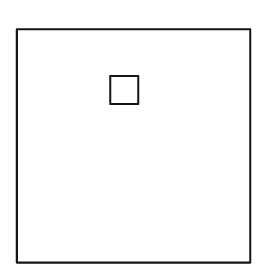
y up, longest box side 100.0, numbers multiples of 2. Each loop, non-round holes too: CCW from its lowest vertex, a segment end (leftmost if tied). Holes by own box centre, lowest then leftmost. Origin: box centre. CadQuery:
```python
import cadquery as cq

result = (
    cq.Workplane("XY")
    .moveTo(-50.0, -50.0)
    .lineTo(50.0, -50.0)
    .lineTo(50.0, 50.0)
    .lineTo(-50.0, 50.0)
    .close()
    .moveTo(-10.0, 18.0)
    .lineTo(2.0, 18.0)
    .lineTo(2.0, 30.0)
    .lineTo(-10.0, 30.0)
    .close()
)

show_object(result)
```